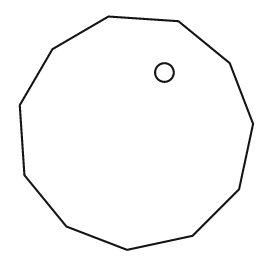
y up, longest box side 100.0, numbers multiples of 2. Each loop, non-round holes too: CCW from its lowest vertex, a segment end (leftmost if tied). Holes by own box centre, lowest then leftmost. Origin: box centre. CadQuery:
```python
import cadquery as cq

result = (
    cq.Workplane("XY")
    .moveTo(-4.0, -50.0)
    .lineTo(24.0, -44.0)
    .lineTo(44.0, -24.0)
    .lineTo(50.0, 4.0)
    .lineTo(40.0, 30.0)
    .lineTo(18.0, 48.0)
    .lineTo(-12.0, 50.0)
    .lineTo(-36.0, 36.0)
    .lineTo(-50.0, 12.0)
    .lineTo(-48.0, -18.0)
    .lineTo(-30.0, -40.0)
    .close()
    .moveTo(12.0, 26.0)
    .circle(4.0)
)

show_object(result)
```